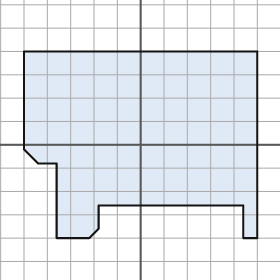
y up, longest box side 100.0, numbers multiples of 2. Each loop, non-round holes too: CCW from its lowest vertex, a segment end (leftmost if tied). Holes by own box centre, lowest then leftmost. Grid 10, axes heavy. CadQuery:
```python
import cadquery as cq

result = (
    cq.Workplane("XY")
    .moveTo(-36.0, -40.0)
    .lineTo(-22.0, -40.0)
    .lineTo(-18.0, -36.0)
    .lineTo(-18.0, -26.0)
    .lineTo(44.0, -26.0)
    .lineTo(44.0, -40.0)
    .lineTo(50.0, -40.0)
    .lineTo(50.0, 40.0)
    .lineTo(-50.0, 40.0)
    .lineTo(-50.0, -2.0)
    .lineTo(-44.0, -8.0)
    .lineTo(-36.0, -8.0)
    .close()
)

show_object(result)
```